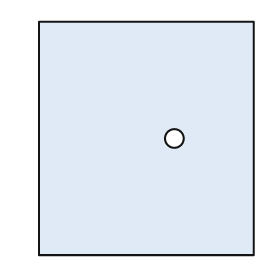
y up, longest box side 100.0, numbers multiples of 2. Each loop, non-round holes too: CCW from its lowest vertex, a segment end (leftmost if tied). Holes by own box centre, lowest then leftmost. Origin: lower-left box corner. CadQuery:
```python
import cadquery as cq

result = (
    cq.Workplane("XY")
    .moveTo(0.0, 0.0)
    .lineTo(92.0, 0.0)
    .lineTo(92.0, 100.0)
    .lineTo(0.0, 100.0)
    .close()
    .moveTo(58.0, 50.0)
    .circle(4.0)
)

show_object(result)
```